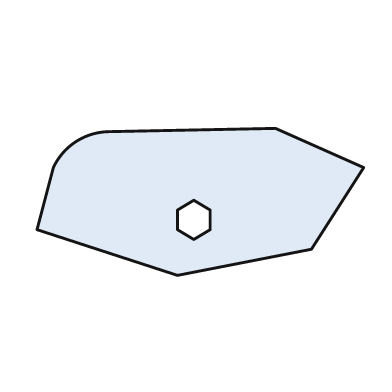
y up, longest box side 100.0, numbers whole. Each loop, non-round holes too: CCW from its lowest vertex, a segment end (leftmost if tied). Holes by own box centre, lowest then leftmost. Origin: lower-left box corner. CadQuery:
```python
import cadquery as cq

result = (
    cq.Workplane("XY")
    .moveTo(43.0, 0.0)
    .lineTo(84.0, 8.0)
    .lineTo(100.0, 33.0)
    .lineTo(73.0, 45.0)
    .lineTo(22.0, 44.0)
    .threePointArc((12.0, 41.0), (5.0, 33.0))
    .lineTo(0.0, 14.0)
    .close()
    .moveTo(48.0, 11.0)
    .lineTo(53.0, 14.0)
    .lineTo(53.0, 20.0)
    .lineTo(48.0, 23.0)
    .lineTo(43.0, 20.0)
    .lineTo(43.0, 14.0)
    .close()
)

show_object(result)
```